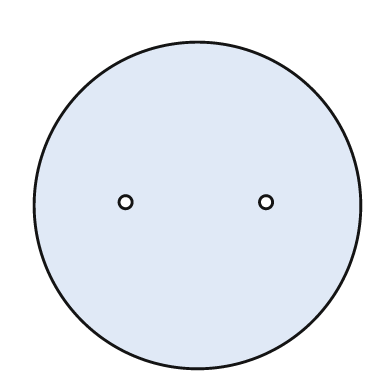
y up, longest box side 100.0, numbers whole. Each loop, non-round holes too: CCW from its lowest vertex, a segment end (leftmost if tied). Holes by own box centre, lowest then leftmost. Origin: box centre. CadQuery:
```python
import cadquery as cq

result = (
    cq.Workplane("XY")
    .moveTo(0.0, 0.0)
    .circle(50.0)
    .moveTo(-22.0, 1.0)
    .circle(2.0)
    .moveTo(21.0, 1.0)
    .circle(2.0)
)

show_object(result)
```